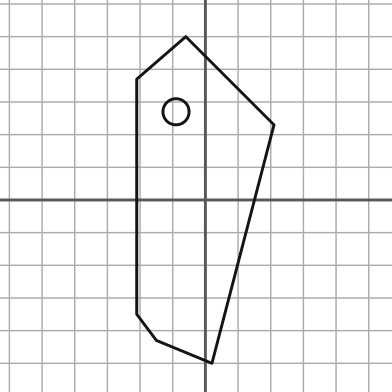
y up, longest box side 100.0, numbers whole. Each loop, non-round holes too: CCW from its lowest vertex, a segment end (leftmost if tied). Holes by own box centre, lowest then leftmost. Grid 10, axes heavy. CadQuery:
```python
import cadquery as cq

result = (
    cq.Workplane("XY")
    .moveTo(2.0, -50.0)
    .lineTo(21.0, 23.0)
    .lineTo(-6.0, 50.0)
    .lineTo(-21.0, 37.0)
    .lineTo(-21.0, -35.0)
    .lineTo(-15.0, -43.0)
    .close()
    .moveTo(-9.0, 27.0)
    .circle(4.0)
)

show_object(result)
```